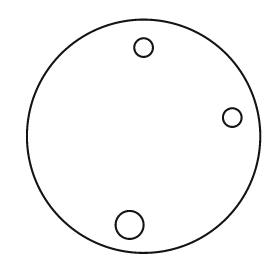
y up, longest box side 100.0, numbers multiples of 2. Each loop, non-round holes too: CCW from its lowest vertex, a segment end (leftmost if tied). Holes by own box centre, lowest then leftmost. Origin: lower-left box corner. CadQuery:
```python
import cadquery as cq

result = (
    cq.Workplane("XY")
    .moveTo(50.0, 50.0)
    .circle(50.0)
    .moveTo(44.0, 12.0)
    .circle(6.0)
    .moveTo(88.0, 58.0)
    .circle(4.0)
    .moveTo(50.0, 88.0)
    .circle(4.0)
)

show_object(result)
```